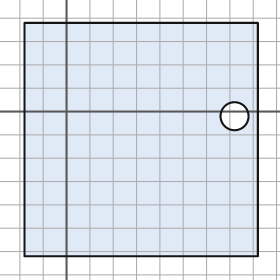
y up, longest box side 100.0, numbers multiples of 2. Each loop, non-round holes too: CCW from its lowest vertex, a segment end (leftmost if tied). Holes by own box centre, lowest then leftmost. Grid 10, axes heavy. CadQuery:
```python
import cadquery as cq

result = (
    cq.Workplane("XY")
    .moveTo(-18.0, -62.0)
    .lineTo(82.0, -62.0)
    .lineTo(82.0, 38.0)
    .lineTo(-18.0, 38.0)
    .close()
    .moveTo(72.0, -2.0)
    .circle(6.0)
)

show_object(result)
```